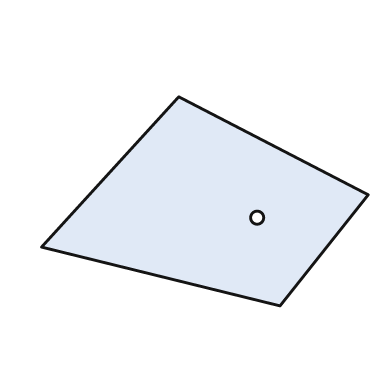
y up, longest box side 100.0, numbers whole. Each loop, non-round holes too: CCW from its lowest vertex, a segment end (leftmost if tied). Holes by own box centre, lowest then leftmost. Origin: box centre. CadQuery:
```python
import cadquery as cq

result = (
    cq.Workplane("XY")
    .moveTo(23.0, -32.0)
    .lineTo(50.0, 2.0)
    .lineTo(-8.0, 32.0)
    .lineTo(-50.0, -14.0)
    .close()
    .moveTo(16.0, -5.0)
    .circle(2.0)
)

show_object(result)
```